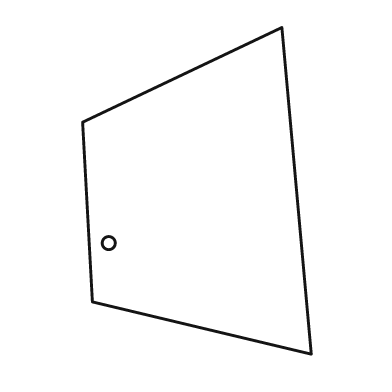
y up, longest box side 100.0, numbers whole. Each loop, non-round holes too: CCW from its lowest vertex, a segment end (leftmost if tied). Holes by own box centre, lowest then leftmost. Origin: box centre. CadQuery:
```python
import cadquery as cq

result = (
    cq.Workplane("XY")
    .moveTo(35.0, -50.0)
    .lineTo(26.0, 50.0)
    .lineTo(-35.0, 21.0)
    .lineTo(-32.0, -34.0)
    .close()
    .moveTo(-27.0, -16.0)
    .circle(2.0)
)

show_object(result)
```